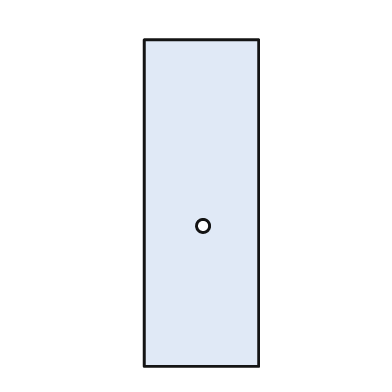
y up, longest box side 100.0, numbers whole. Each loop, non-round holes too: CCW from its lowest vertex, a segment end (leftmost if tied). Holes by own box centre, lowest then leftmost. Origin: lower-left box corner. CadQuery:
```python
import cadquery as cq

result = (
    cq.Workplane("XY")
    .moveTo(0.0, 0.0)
    .lineTo(35.0, 0.0)
    .lineTo(35.0, 100.0)
    .lineTo(0.0, 100.0)
    .close()
    .moveTo(18.0, 43.0)
    .circle(2.0)
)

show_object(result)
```